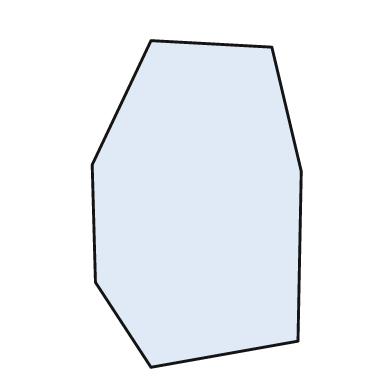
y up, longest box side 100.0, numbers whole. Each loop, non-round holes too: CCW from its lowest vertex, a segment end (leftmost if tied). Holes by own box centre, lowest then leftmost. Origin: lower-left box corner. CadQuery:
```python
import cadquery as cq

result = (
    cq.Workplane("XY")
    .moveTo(18.0, 0.0)
    .lineTo(63.0, 8.0)
    .lineTo(64.0, 60.0)
    .lineTo(55.0, 98.0)
    .lineTo(18.0, 100.0)
    .lineTo(0.0, 62.0)
    .lineTo(1.0, 26.0)
    .close()
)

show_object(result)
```